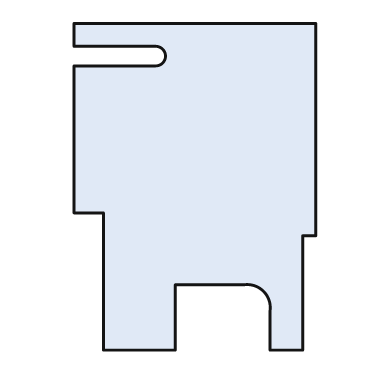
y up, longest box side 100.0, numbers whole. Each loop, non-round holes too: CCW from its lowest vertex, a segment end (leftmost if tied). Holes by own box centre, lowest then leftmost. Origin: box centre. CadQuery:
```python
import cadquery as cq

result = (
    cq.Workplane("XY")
    .moveTo(-28.0, -50.0)
    .lineTo(-6.0, -50.0)
    .lineTo(-6.0, -30.0)
    .lineTo(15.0, -30.0)
    .threePointArc((21.0, -32.0), (23.0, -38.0))
    .lineTo(23.0, -50.0)
    .lineTo(33.0, -50.0)
    .lineTo(33.0, -15.0)
    .lineTo(37.0, -15.0)
    .lineTo(37.0, 50.0)
    .lineTo(-37.0, 50.0)
    .lineTo(-37.0, 43.0)
    .lineTo(-12.0, 43.0)
    .threePointArc((-9.0, 40.0), (-12.0, 37.0))
    .lineTo(-37.0, 37.0)
    .lineTo(-37.0, -8.0)
    .lineTo(-28.0, -8.0)
    .close()
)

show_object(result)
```